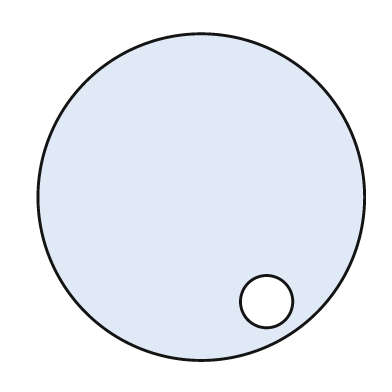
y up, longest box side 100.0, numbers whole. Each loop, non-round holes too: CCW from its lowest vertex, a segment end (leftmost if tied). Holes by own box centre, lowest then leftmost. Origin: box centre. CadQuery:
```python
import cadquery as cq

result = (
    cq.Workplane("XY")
    .moveTo(0.0, 0.0)
    .circle(50.0)
    .moveTo(20.0, -32.0)
    .circle(8.0)
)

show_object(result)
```